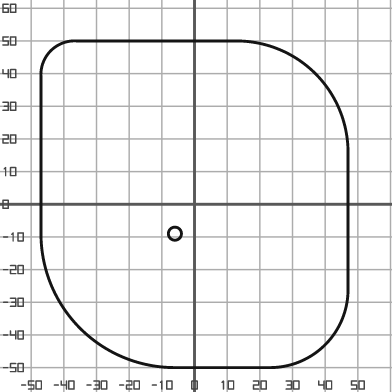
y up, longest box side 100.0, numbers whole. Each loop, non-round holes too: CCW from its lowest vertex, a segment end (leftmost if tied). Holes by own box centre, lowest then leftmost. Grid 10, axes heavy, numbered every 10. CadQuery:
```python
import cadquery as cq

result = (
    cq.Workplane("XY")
    .moveTo(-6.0, -50.0)
    .lineTo(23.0, -50.0)
    .threePointArc((40.0, -43.0), (47.0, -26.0))
    .lineTo(47.0, 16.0)
    .threePointArc((37.0, 40.0), (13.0, 50.0))
    .lineTo(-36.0, 50.0)
    .threePointArc((-44.0, 47.0), (-47.0, 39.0))
    .lineTo(-47.0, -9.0)
    .threePointArc((-35.0, -38.0), (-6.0, -50.0))
    .close()
    .moveTo(-6.0, -9.0)
    .circle(2.0)
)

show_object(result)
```